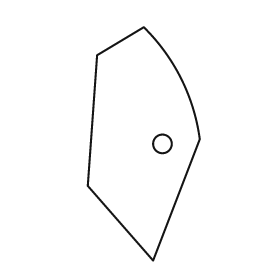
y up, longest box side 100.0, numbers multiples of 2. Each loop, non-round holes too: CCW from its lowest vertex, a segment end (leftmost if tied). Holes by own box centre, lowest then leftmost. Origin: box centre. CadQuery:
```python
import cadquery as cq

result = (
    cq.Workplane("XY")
    .moveTo(4.0, -50.0)
    .lineTo(24.0, 2.0)
    .threePointArc((16.0, 28.0), (0.0, 50.0))
    .lineTo(-20.0, 38.0)
    .lineTo(-24.0, -18.0)
    .close()
    .moveTo(8.0, 0.0)
    .circle(4.0)
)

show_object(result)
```